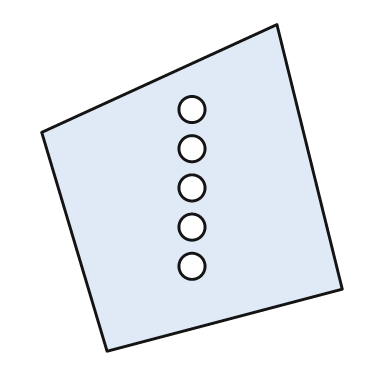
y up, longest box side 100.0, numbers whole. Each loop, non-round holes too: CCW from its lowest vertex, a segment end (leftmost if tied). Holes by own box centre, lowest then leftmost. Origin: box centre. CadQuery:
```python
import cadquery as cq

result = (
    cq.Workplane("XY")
    .moveTo(-26.0, -50.0)
    .lineTo(46.0, -31.0)
    .lineTo(26.0, 50.0)
    .lineTo(-46.0, 17.0)
    .close()
    .moveTo(0.0, -24.0)
    .circle(4.0)
    .moveTo(0.0, -12.0)
    .circle(4.0)
    .moveTo(0.0, 0.0)
    .circle(4.0)
    .moveTo(0.0, 12.0)
    .circle(4.0)
    .moveTo(0.0, 24.0)
    .circle(4.0)
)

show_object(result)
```